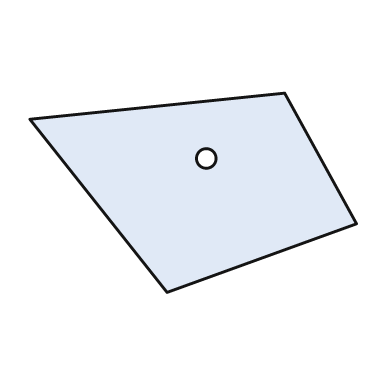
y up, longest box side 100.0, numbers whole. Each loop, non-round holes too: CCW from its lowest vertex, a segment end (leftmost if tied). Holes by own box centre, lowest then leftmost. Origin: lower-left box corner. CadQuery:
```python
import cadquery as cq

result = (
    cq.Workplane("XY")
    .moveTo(42.0, 0.0)
    .lineTo(100.0, 21.0)
    .lineTo(78.0, 61.0)
    .lineTo(0.0, 53.0)
    .close()
    .moveTo(54.0, 41.0)
    .circle(3.0)
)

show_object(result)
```